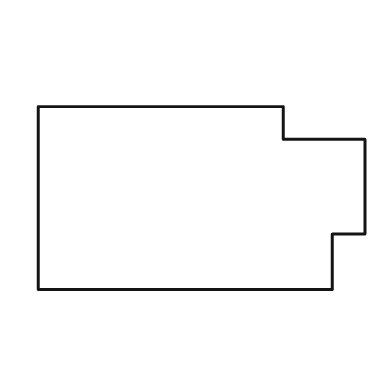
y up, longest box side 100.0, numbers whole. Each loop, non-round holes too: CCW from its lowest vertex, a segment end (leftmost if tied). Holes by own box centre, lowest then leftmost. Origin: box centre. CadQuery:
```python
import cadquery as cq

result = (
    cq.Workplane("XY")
    .moveTo(-50.0, -28.0)
    .lineTo(40.0, -28.0)
    .lineTo(40.0, -11.0)
    .lineTo(50.0, -11.0)
    .lineTo(50.0, 18.0)
    .lineTo(25.0, 18.0)
    .lineTo(25.0, 28.0)
    .lineTo(-50.0, 28.0)
    .close()
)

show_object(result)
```